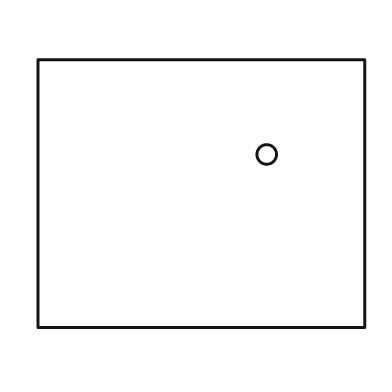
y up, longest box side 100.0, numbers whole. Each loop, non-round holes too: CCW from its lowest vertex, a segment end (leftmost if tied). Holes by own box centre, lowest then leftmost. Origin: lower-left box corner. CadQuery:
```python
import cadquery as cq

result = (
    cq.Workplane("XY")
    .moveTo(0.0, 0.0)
    .lineTo(100.0, 0.0)
    .lineTo(100.0, 82.0)
    .lineTo(0.0, 82.0)
    .close()
    .moveTo(70.0, 53.0)
    .circle(3.0)
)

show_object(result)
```